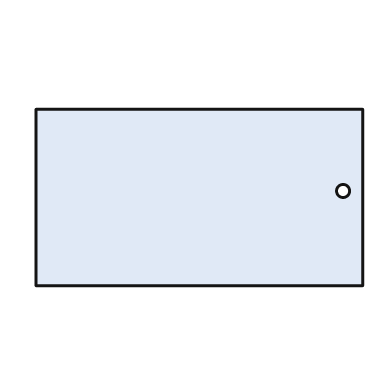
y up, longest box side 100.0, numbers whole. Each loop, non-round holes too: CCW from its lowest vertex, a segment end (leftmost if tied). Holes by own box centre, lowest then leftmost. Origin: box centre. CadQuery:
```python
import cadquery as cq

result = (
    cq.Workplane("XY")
    .moveTo(-50.0, -27.0)
    .lineTo(50.0, -27.0)
    .lineTo(50.0, 27.0)
    .lineTo(-50.0, 27.0)
    .close()
    .moveTo(44.0, 2.0)
    .circle(2.0)
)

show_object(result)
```